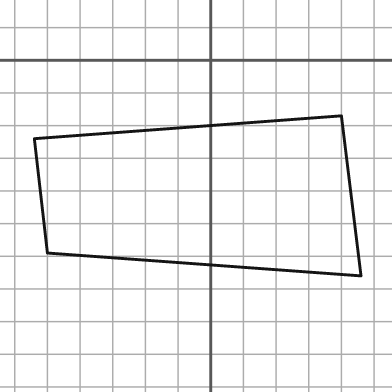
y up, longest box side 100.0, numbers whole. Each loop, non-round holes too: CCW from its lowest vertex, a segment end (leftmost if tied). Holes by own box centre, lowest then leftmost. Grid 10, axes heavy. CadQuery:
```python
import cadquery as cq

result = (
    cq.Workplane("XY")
    .moveTo(46.0, -66.0)
    .lineTo(40.0, -17.0)
    .lineTo(-54.0, -24.0)
    .lineTo(-50.0, -59.0)
    .close()
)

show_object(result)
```